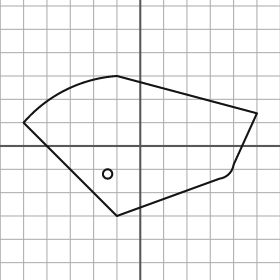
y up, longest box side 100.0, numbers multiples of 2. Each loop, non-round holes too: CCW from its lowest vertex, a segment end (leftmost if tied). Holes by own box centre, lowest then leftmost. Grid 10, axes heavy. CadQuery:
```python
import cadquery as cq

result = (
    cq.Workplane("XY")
    .moveTo(-10.0, -30.0)
    .lineTo(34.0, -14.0)
    .threePointArc((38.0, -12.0), (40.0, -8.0))
    .lineTo(50.0, 14.0)
    .lineTo(-10.0, 30.0)
    .threePointArc((-32.0, 24.0), (-50.0, 10.0))
    .close()
    .moveTo(-14.0, -12.0)
    .circle(2.0)
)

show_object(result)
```